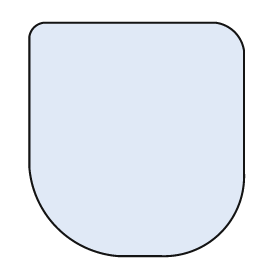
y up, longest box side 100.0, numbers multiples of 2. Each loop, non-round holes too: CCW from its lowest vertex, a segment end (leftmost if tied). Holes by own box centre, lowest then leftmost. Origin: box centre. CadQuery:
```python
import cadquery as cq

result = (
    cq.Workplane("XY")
    .moveTo(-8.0, -50.0)
    .lineTo(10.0, -50.0)
    .threePointArc((36.0, -40.0), (46.0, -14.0))
    .lineTo(46.0, 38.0)
    .threePointArc((42.0, 46.0), (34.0, 50.0))
    .lineTo(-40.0, 50.0)
    .threePointArc((-44.0, 48.0), (-46.0, 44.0))
    .lineTo(-46.0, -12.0)
    .threePointArc((-34.0, -38.0), (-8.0, -50.0))
    .close()
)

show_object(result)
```